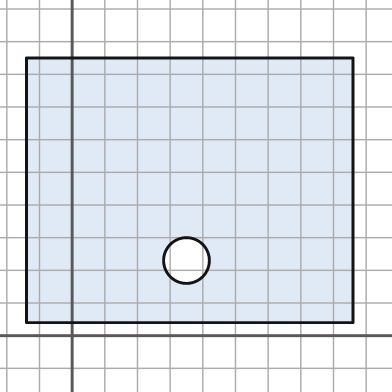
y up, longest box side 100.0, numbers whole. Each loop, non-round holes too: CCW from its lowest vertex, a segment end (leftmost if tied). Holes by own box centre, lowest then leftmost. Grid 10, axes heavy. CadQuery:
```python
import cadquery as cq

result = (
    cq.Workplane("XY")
    .moveTo(-14.0, 4.0)
    .lineTo(86.0, 4.0)
    .lineTo(86.0, 85.0)
    .lineTo(-14.0, 85.0)
    .close()
    .moveTo(35.0, 23.0)
    .circle(7.0)
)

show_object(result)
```